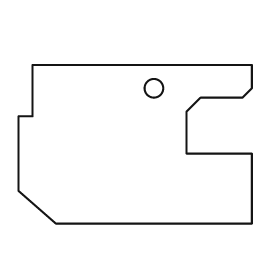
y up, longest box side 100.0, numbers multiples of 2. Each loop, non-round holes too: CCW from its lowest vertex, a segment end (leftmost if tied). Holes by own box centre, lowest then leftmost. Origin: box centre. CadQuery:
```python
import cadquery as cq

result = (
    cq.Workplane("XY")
    .moveTo(-34.0, -34.0)
    .lineTo(50.0, -34.0)
    .lineTo(50.0, -4.0)
    .lineTo(22.0, -4.0)
    .lineTo(22.0, 14.0)
    .lineTo(28.0, 20.0)
    .lineTo(46.0, 20.0)
    .lineTo(50.0, 24.0)
    .lineTo(50.0, 34.0)
    .lineTo(-44.0, 34.0)
    .lineTo(-44.0, 12.0)
    .lineTo(-50.0, 12.0)
    .lineTo(-50.0, -20.0)
    .close()
    .moveTo(8.0, 24.0)
    .circle(4.0)
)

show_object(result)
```